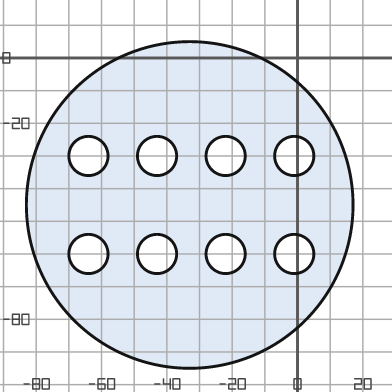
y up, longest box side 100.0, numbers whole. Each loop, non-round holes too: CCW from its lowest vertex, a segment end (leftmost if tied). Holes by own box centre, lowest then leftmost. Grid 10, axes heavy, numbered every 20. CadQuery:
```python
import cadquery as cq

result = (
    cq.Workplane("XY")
    .moveTo(-33.0, -45.0)
    .circle(50.0)
    .moveTo(-64.0, -60.0)
    .circle(6.0)
    .moveTo(-43.0, -60.0)
    .circle(6.0)
    .moveTo(-22.0, -60.0)
    .circle(6.0)
    .moveTo(-1.0, -60.0)
    .circle(6.0)
    .moveTo(-64.0, -30.0)
    .circle(6.0)
    .moveTo(-43.0, -30.0)
    .circle(6.0)
    .moveTo(-22.0, -30.0)
    .circle(6.0)
    .moveTo(-1.0, -30.0)
    .circle(6.0)
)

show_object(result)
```